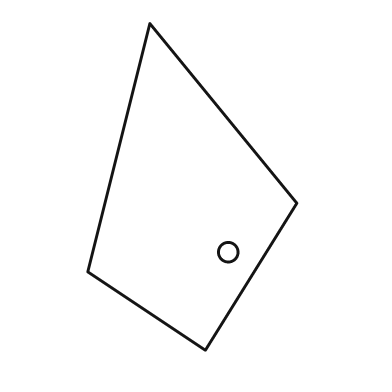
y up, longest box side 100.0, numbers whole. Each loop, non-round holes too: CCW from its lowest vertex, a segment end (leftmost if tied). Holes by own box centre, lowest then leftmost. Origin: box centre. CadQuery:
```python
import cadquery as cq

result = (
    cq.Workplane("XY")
    .moveTo(4.0, -50.0)
    .lineTo(32.0, -5.0)
    .lineTo(-13.0, 50.0)
    .lineTo(-32.0, -26.0)
    .close()
    .moveTo(11.0, -20.0)
    .circle(3.0)
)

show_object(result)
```